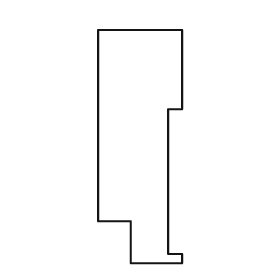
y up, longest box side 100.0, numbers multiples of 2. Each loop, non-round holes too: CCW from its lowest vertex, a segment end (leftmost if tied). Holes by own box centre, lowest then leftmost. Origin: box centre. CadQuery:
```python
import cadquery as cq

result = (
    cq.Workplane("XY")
    .moveTo(-4.0, -50.0)
    .lineTo(18.0, -50.0)
    .lineTo(18.0, -46.0)
    .lineTo(12.0, -46.0)
    .lineTo(12.0, 16.0)
    .lineTo(18.0, 16.0)
    .lineTo(18.0, 50.0)
    .lineTo(-18.0, 50.0)
    .lineTo(-18.0, -32.0)
    .lineTo(-4.0, -32.0)
    .close()
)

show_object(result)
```